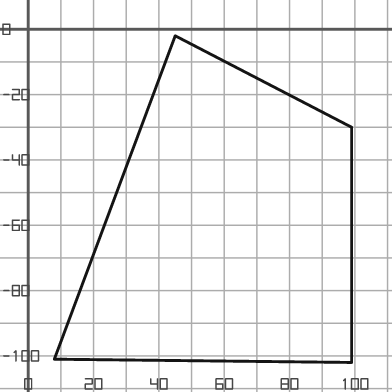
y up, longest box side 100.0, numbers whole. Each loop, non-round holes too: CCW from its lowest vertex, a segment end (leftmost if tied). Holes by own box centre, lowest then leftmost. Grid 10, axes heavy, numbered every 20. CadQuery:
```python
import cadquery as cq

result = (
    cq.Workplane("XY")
    .moveTo(99.0, -102.0)
    .lineTo(99.0, -30.0)
    .lineTo(45.0, -2.0)
    .lineTo(8.0, -101.0)
    .close()
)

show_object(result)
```